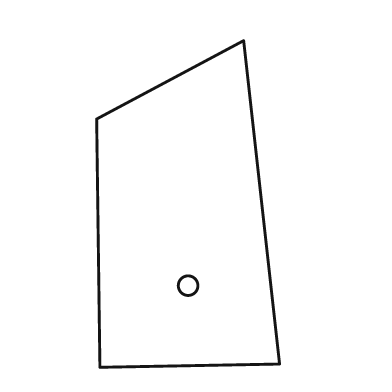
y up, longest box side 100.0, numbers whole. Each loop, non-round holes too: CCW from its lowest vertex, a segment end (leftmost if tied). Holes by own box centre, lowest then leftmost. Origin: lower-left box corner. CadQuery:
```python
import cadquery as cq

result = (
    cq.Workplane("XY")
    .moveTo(1.0, 0.0)
    .lineTo(56.0, 1.0)
    .lineTo(45.0, 100.0)
    .lineTo(0.0, 76.0)
    .close()
    .moveTo(28.0, 25.0)
    .circle(3.0)
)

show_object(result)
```